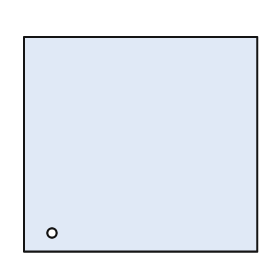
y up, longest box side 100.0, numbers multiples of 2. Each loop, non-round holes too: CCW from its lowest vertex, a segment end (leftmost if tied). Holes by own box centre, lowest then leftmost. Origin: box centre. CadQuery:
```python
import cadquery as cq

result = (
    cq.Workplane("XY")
    .moveTo(-50.0, -46.0)
    .lineTo(50.0, -46.0)
    .lineTo(50.0, 46.0)
    .lineTo(-50.0, 46.0)
    .close()
    .moveTo(-38.0, -38.0)
    .circle(2.0)
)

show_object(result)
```